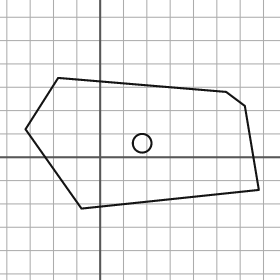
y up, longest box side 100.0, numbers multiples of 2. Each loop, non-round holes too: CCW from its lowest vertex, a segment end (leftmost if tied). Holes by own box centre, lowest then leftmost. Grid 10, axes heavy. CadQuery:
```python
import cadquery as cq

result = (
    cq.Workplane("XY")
    .moveTo(-8.0, -22.0)
    .lineTo(68.0, -14.0)
    .lineTo(62.0, 22.0)
    .lineTo(54.0, 28.0)
    .lineTo(-18.0, 34.0)
    .lineTo(-32.0, 12.0)
    .close()
    .moveTo(18.0, 6.0)
    .circle(4.0)
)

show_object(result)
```